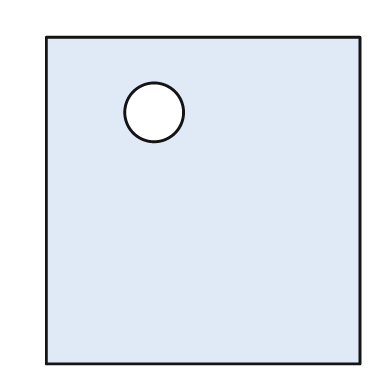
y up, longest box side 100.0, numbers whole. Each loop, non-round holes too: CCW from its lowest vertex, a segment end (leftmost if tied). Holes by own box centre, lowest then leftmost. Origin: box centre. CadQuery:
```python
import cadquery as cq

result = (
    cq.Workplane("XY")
    .moveTo(-48.0, -50.0)
    .lineTo(48.0, -50.0)
    .lineTo(48.0, 50.0)
    .lineTo(-48.0, 50.0)
    .close()
    .moveTo(-15.0, 27.0)
    .circle(9.0)
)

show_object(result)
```